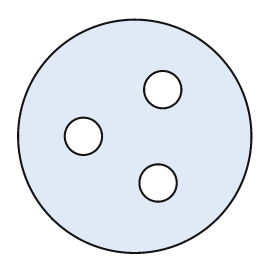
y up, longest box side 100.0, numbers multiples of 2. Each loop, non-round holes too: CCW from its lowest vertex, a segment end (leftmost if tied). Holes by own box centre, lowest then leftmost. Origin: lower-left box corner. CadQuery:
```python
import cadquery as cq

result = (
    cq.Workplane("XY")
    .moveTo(50.0, 50.0)
    .circle(50.0)
    .moveTo(60.0, 30.0)
    .circle(8.0)
    .moveTo(28.0, 50.0)
    .circle(8.0)
    .moveTo(62.0, 70.0)
    .circle(8.0)
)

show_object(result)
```